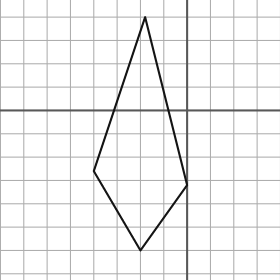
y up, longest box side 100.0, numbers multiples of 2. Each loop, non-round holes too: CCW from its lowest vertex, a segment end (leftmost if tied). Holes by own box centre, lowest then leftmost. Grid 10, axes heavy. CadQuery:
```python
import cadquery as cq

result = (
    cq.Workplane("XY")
    .moveTo(-20.0, -60.0)
    .lineTo(0.0, -32.0)
    .lineTo(-18.0, 40.0)
    .lineTo(-40.0, -26.0)
    .close()
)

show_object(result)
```